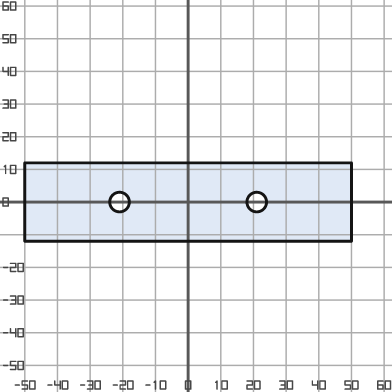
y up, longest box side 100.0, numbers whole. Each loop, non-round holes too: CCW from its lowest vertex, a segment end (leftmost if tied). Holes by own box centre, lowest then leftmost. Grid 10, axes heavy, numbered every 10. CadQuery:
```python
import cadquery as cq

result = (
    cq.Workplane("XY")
    .moveTo(-50.0, -12.0)
    .lineTo(50.0, -12.0)
    .lineTo(50.0, 12.0)
    .lineTo(-50.0, 12.0)
    .close()
    .moveTo(-21.0, 0.0)
    .circle(3.0)
    .moveTo(21.0, 0.0)
    .circle(3.0)
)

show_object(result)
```